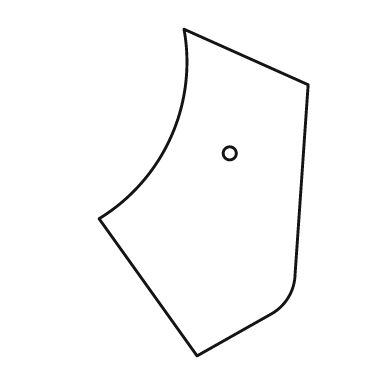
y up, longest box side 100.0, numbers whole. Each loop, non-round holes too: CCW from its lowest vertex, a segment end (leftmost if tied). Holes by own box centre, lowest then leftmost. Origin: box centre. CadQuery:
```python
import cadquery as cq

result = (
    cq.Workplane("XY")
    .moveTo(-2.0, -50.0)
    .lineTo(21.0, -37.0)
    .threePointArc((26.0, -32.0), (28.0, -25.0))
    .lineTo(32.0, 33.0)
    .lineTo(-6.0, 50.0)
    .threePointArc((-10.0, 17.0), (-32.0, -8.0))
    .close()
    .moveTo(8.0, 12.0)
    .circle(2.0)
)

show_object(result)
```